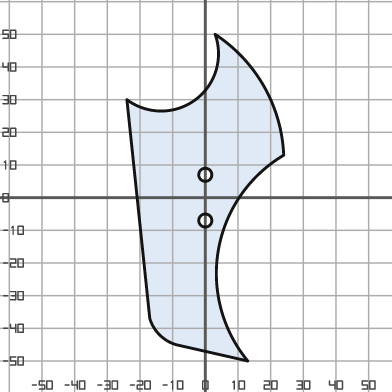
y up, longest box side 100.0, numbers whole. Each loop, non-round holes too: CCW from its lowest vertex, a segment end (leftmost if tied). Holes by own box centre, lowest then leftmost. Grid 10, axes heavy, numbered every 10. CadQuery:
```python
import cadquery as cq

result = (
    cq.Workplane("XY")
    .moveTo(13.0, -50.0)
    .threePointArc((4.0, -16.0), (24.0, 13.0))
    .threePointArc((18.0, 34.0), (3.0, 50.0))
    .threePointArc((-3.0, 30.0), (-24.0, 30.0))
    .lineTo(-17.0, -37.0)
    .threePointArc((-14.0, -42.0), (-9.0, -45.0))
    .close()
    .moveTo(0.0, -7.0)
    .circle(2.0)
    .moveTo(0.0, 7.0)
    .circle(2.0)
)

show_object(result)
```